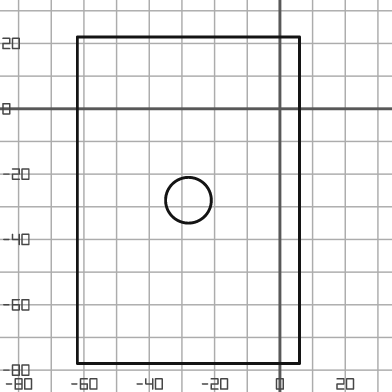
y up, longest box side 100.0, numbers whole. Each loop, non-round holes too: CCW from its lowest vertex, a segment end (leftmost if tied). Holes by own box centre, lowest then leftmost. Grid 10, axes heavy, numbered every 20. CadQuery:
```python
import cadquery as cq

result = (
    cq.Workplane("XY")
    .moveTo(-62.0, -78.0)
    .lineTo(6.0, -78.0)
    .lineTo(6.0, 22.0)
    .lineTo(-62.0, 22.0)
    .close()
    .moveTo(-28.0, -28.0)
    .circle(7.0)
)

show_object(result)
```